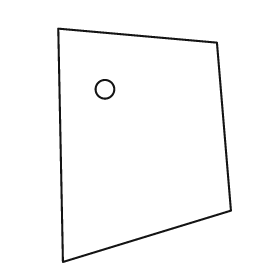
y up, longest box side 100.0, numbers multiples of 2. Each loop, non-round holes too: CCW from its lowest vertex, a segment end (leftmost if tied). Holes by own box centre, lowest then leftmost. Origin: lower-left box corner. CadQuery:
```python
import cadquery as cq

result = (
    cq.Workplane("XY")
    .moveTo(2.0, 0.0)
    .lineTo(74.0, 22.0)
    .lineTo(68.0, 94.0)
    .lineTo(0.0, 100.0)
    .close()
    .moveTo(20.0, 74.0)
    .circle(4.0)
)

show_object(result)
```